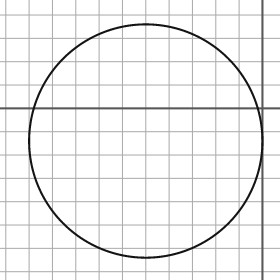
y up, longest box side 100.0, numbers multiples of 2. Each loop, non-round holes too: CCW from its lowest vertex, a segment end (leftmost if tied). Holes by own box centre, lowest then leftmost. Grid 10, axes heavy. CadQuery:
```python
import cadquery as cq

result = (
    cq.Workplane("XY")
    .moveTo(-50.0, -14.0)
    .circle(50.0)
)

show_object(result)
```